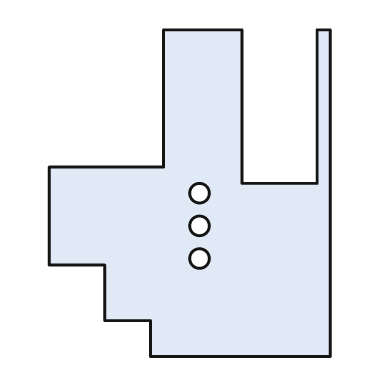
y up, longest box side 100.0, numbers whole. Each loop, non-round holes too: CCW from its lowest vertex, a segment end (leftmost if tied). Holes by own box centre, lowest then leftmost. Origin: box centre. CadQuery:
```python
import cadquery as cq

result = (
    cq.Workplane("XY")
    .moveTo(-12.0, -50.0)
    .lineTo(43.0, -50.0)
    .lineTo(43.0, 50.0)
    .lineTo(39.0, 50.0)
    .lineTo(39.0, 3.0)
    .lineTo(16.0, 3.0)
    .lineTo(16.0, 50.0)
    .lineTo(-8.0, 50.0)
    .lineTo(-8.0, 8.0)
    .lineTo(-43.0, 8.0)
    .lineTo(-43.0, -22.0)
    .lineTo(-26.0, -22.0)
    .lineTo(-26.0, -39.0)
    .lineTo(-12.0, -39.0)
    .close()
    .moveTo(3.0, -20.0)
    .circle(3.0)
    .moveTo(3.0, -10.0)
    .circle(3.0)
    .moveTo(3.0, 0.0)
    .circle(3.0)
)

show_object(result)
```